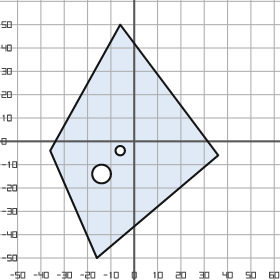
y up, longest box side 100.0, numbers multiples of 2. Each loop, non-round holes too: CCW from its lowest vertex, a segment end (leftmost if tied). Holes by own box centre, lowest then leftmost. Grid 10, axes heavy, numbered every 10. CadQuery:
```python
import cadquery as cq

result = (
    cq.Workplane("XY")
    .moveTo(-16.0, -50.0)
    .lineTo(36.0, -6.0)
    .lineTo(-6.0, 50.0)
    .lineTo(-36.0, -4.0)
    .close()
    .moveTo(-14.0, -14.0)
    .circle(4.0)
    .moveTo(-6.0, -4.0)
    .circle(2.0)
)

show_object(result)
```